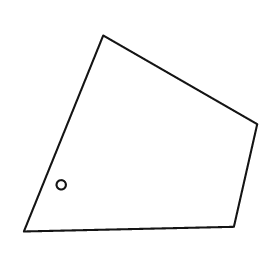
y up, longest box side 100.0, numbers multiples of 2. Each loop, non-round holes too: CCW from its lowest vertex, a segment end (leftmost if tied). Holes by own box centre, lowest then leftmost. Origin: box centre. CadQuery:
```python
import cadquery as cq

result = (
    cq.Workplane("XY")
    .moveTo(-50.0, -42.0)
    .lineTo(40.0, -40.0)
    .lineTo(50.0, 4.0)
    .lineTo(-16.0, 42.0)
    .close()
    .moveTo(-34.0, -22.0)
    .circle(2.0)
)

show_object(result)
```